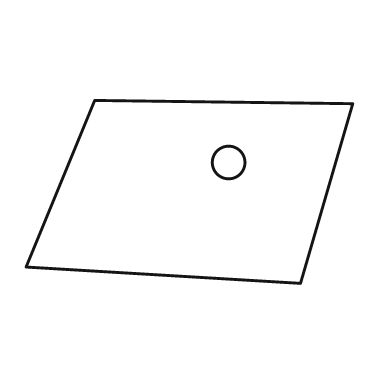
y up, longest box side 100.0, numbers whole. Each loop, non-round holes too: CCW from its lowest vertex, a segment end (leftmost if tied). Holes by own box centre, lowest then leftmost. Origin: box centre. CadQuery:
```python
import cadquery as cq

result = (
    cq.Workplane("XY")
    .moveTo(34.0, -28.0)
    .lineTo(50.0, 27.0)
    .lineTo(-29.0, 28.0)
    .lineTo(-50.0, -23.0)
    .close()
    .moveTo(12.0, 9.0)
    .circle(5.0)
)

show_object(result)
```